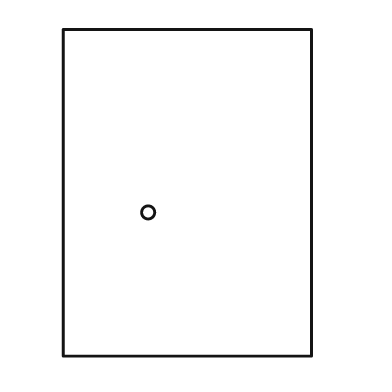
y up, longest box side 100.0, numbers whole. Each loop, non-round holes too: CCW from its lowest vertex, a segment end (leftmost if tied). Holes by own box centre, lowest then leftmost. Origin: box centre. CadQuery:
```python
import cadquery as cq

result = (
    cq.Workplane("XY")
    .moveTo(-38.0, -50.0)
    .lineTo(38.0, -50.0)
    .lineTo(38.0, 50.0)
    .lineTo(-38.0, 50.0)
    .close()
    .moveTo(-12.0, -6.0)
    .circle(2.0)
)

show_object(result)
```